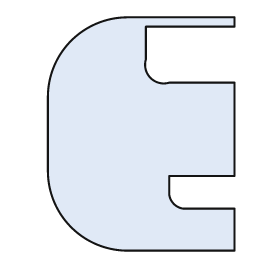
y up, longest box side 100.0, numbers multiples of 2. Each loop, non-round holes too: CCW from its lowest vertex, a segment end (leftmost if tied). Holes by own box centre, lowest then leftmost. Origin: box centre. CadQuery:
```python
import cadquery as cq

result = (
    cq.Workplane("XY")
    .moveTo(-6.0, -50.0)
    .lineTo(40.0, -50.0)
    .lineTo(40.0, -32.0)
    .lineTo(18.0, -32.0)
    .threePointArc((14.0, -30.0), (12.0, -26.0))
    .lineTo(12.0, -18.0)
    .lineTo(40.0, -18.0)
    .lineTo(40.0, 22.0)
    .lineTo(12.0, 22.0)
    .threePointArc((4.0, 24.0), (2.0, 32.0))
    .lineTo(2.0, 46.0)
    .lineTo(40.0, 46.0)
    .lineTo(40.0, 50.0)
    .lineTo(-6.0, 50.0)
    .threePointArc((-30.0, 40.0), (-40.0, 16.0))
    .lineTo(-40.0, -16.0)
    .threePointArc((-30.0, -40.0), (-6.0, -50.0))
    .close()
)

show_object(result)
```